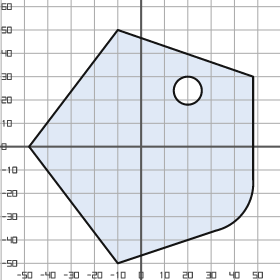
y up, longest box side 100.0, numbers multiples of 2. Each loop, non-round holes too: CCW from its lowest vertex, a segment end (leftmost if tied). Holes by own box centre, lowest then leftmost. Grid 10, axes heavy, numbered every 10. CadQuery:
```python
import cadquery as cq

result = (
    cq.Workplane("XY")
    .moveTo(-10.0, -50.0)
    .lineTo(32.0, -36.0)
    .threePointArc((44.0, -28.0), (48.0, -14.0))
    .lineTo(48.0, 30.0)
    .lineTo(-10.0, 50.0)
    .lineTo(-48.0, 0.0)
    .close()
    .moveTo(20.0, 24.0)
    .circle(6.0)
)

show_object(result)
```